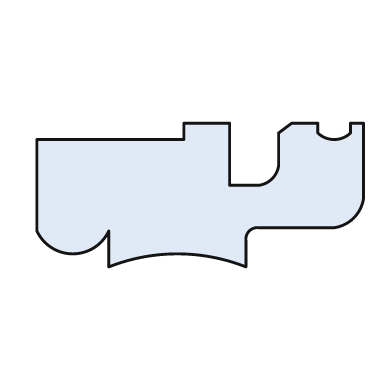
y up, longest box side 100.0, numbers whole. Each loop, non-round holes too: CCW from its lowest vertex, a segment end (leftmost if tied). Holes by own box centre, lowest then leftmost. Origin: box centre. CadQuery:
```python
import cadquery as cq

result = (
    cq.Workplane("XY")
    .moveTo(-28.0, -22.0)
    .threePointArc((-7.0, -18.0), (14.0, -22.0))
    .lineTo(14.0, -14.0)
    .threePointArc((15.0, -11.0), (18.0, -10.0))
    .lineTo(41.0, -10.0)
    .threePointArc((47.0, -7.0), (50.0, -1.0))
    .lineTo(50.0, 22.0)
    .lineTo(46.0, 22.0)
    .lineTo(46.0, 19.0)
    .threePointArc((41.0, 17.0), (36.0, 19.0))
    .lineTo(36.0, 22.0)
    .lineTo(28.0, 22.0)
    .lineTo(24.0, 19.0)
    .lineTo(24.0, 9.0)
    .threePointArc((22.0, 5.0), (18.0, 3.0))
    .lineTo(9.0, 3.0)
    .lineTo(9.0, 22.0)
    .lineTo(-5.0, 22.0)
    .lineTo(-5.0, 17.0)
    .lineTo(-50.0, 17.0)
    .lineTo(-50.0, -11.0)
    .threePointArc((-39.0, -18.0), (-28.0, -11.0))
    .close()
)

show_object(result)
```